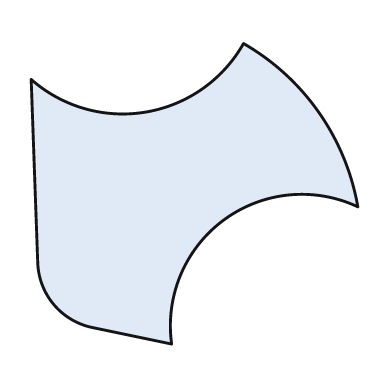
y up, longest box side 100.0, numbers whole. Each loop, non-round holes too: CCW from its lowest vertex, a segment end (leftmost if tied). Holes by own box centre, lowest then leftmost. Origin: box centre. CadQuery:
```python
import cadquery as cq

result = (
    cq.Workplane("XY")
    .moveTo(-7.0, -46.0)
    .threePointArc((9.0, -8.0), (50.0, -4.0))
    .threePointArc((38.0, 25.0), (15.0, 46.0))
    .threePointArc((-15.0, 25.0), (-50.0, 35.0))
    .lineTo(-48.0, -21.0)
    .threePointArc((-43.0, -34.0), (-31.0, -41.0))
    .close()
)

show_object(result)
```